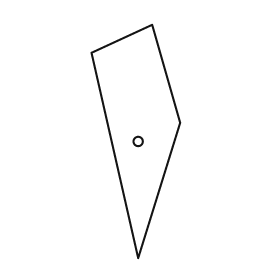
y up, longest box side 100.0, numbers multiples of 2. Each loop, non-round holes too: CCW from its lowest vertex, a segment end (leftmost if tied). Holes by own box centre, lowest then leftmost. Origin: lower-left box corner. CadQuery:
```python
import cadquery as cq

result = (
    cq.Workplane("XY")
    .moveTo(20.0, 0.0)
    .lineTo(38.0, 58.0)
    .lineTo(26.0, 100.0)
    .lineTo(0.0, 88.0)
    .close()
    .moveTo(20.0, 50.0)
    .circle(2.0)
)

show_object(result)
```